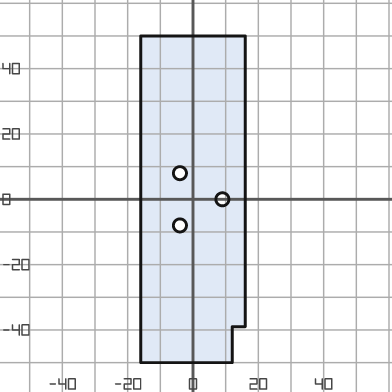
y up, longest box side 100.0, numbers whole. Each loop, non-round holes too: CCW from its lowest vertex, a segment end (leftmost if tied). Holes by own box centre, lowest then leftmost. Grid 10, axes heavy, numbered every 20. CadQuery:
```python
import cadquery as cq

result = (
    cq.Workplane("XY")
    .moveTo(-16.0, -50.0)
    .lineTo(12.0, -50.0)
    .lineTo(12.0, -39.0)
    .lineTo(16.0, -39.0)
    .lineTo(16.0, 50.0)
    .lineTo(-16.0, 50.0)
    .close()
    .moveTo(-4.0, -8.0)
    .circle(2.0)
    .moveTo(9.0, 0.0)
    .circle(2.0)
    .moveTo(-4.0, 8.0)
    .circle(2.0)
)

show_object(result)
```